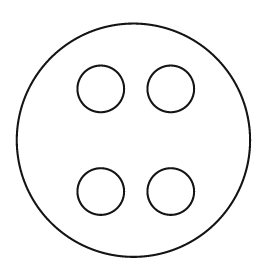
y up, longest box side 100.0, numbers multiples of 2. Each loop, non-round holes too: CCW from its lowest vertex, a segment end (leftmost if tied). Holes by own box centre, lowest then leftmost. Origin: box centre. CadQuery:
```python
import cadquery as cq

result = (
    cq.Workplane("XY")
    .moveTo(0.0, 0.0)
    .circle(50.0)
    .moveTo(-14.0, -22.0)
    .circle(10.0)
    .moveTo(16.0, -22.0)
    .circle(10.0)
    .moveTo(-14.0, 22.0)
    .circle(10.0)
    .moveTo(16.0, 22.0)
    .circle(10.0)
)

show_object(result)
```